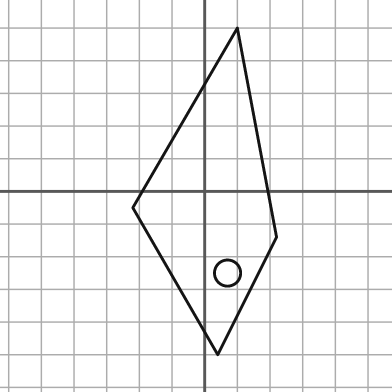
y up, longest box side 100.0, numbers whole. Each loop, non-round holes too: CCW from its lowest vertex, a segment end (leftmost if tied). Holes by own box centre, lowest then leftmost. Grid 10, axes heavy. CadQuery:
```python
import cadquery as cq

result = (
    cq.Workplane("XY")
    .moveTo(4.0, -50.0)
    .lineTo(22.0, -14.0)
    .lineTo(10.0, 50.0)
    .lineTo(-22.0, -5.0)
    .close()
    .moveTo(7.0, -25.0)
    .circle(4.0)
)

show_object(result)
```